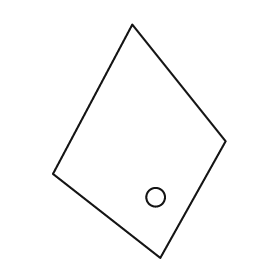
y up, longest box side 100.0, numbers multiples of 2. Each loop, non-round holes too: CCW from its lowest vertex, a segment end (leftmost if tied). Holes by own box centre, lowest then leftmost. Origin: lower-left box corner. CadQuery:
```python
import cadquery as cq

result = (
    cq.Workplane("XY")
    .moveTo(46.0, 0.0)
    .lineTo(74.0, 50.0)
    .lineTo(34.0, 100.0)
    .lineTo(0.0, 36.0)
    .close()
    .moveTo(44.0, 26.0)
    .circle(4.0)
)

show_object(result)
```